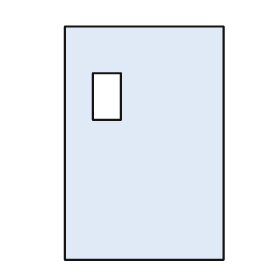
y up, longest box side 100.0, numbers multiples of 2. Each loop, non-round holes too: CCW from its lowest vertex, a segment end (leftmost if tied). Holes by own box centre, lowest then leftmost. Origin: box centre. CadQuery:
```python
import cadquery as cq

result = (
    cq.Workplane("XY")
    .moveTo(-34.0, -50.0)
    .lineTo(34.0, -50.0)
    .lineTo(34.0, 50.0)
    .lineTo(-34.0, 50.0)
    .close()
    .moveTo(-22.0, 10.0)
    .lineTo(-10.0, 10.0)
    .lineTo(-10.0, 30.0)
    .lineTo(-22.0, 30.0)
    .close()
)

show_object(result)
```